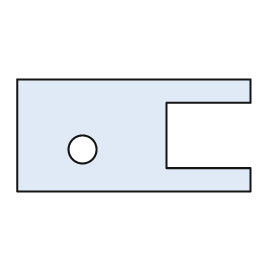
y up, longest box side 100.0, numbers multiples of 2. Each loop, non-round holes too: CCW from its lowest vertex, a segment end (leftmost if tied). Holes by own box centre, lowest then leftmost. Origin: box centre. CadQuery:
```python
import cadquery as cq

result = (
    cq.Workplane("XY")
    .moveTo(-50.0, -24.0)
    .lineTo(50.0, -24.0)
    .lineTo(50.0, -14.0)
    .lineTo(14.0, -14.0)
    .lineTo(14.0, 14.0)
    .lineTo(50.0, 14.0)
    .lineTo(50.0, 24.0)
    .lineTo(-50.0, 24.0)
    .close()
    .moveTo(-22.0, -6.0)
    .circle(6.0)
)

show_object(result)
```